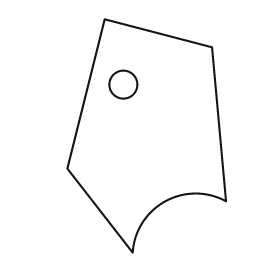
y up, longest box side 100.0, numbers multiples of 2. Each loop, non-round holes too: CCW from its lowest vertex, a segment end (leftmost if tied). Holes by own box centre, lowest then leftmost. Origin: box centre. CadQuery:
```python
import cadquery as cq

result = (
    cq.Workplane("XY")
    .moveTo(-6.0, -50.0)
    .threePointArc((8.0, -28.0), (34.0, -28.0))
    .lineTo(28.0, 38.0)
    .lineTo(-18.0, 50.0)
    .lineTo(-34.0, -14.0)
    .close()
    .moveTo(-10.0, 22.0)
    .circle(6.0)
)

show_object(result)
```